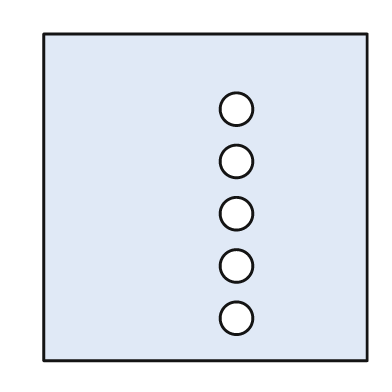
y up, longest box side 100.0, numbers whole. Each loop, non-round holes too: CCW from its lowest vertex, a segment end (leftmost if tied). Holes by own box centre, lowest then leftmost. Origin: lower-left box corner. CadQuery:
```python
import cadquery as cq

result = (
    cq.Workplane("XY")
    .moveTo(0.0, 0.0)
    .lineTo(99.0, 0.0)
    .lineTo(99.0, 100.0)
    .lineTo(0.0, 100.0)
    .close()
    .moveTo(59.0, 13.0)
    .circle(5.0)
    .moveTo(59.0, 29.0)
    .circle(5.0)
    .moveTo(59.0, 45.0)
    .circle(5.0)
    .moveTo(59.0, 61.0)
    .circle(5.0)
    .moveTo(59.0, 77.0)
    .circle(5.0)
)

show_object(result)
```